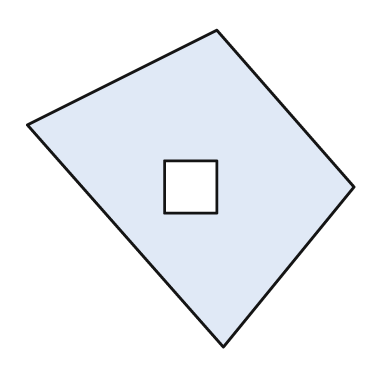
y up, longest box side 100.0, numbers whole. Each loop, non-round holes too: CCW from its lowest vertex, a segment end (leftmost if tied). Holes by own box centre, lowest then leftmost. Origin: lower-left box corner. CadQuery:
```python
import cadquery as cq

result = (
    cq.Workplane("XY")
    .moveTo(60.0, 0.0)
    .lineTo(100.0, 49.0)
    .lineTo(58.0, 97.0)
    .lineTo(0.0, 68.0)
    .close()
    .moveTo(42.0, 41.0)
    .lineTo(58.0, 41.0)
    .lineTo(58.0, 57.0)
    .lineTo(42.0, 57.0)
    .close()
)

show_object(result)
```